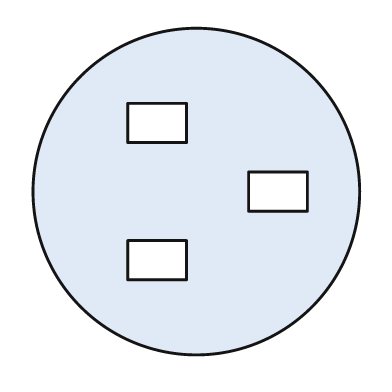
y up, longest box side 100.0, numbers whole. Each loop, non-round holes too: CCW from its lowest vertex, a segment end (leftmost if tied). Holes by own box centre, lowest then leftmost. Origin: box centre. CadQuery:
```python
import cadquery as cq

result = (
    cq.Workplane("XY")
    .moveTo(0.0, 0.0)
    .circle(50.0)
    .moveTo(-21.0, -27.0)
    .lineTo(-3.0, -27.0)
    .lineTo(-3.0, -15.0)
    .lineTo(-21.0, -15.0)
    .close()
    .moveTo(16.0, -6.0)
    .lineTo(34.0, -6.0)
    .lineTo(34.0, 6.0)
    .lineTo(16.0, 6.0)
    .close()
    .moveTo(-21.0, 15.0)
    .lineTo(-3.0, 15.0)
    .lineTo(-3.0, 27.0)
    .lineTo(-21.0, 27.0)
    .close()
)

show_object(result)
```